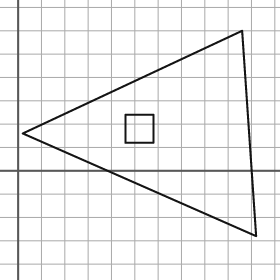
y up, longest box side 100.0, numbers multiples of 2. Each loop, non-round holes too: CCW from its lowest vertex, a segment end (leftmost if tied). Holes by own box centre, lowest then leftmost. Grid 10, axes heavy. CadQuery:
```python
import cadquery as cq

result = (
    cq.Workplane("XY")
    .moveTo(102.0, -28.0)
    .lineTo(96.0, 60.0)
    .lineTo(2.0, 16.0)
    .close()
    .moveTo(46.0, 12.0)
    .lineTo(58.0, 12.0)
    .lineTo(58.0, 24.0)
    .lineTo(46.0, 24.0)
    .close()
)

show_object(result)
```